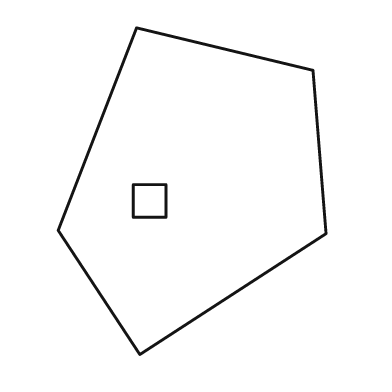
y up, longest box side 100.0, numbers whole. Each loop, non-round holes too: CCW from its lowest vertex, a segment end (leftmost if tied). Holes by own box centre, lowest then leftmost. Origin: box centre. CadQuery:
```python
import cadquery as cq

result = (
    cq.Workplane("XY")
    .moveTo(-16.0, -50.0)
    .lineTo(41.0, -13.0)
    .lineTo(37.0, 37.0)
    .lineTo(-17.0, 50.0)
    .lineTo(-41.0, -12.0)
    .close()
    .moveTo(-18.0, -8.0)
    .lineTo(-8.0, -8.0)
    .lineTo(-8.0, 2.0)
    .lineTo(-18.0, 2.0)
    .close()
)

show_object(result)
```